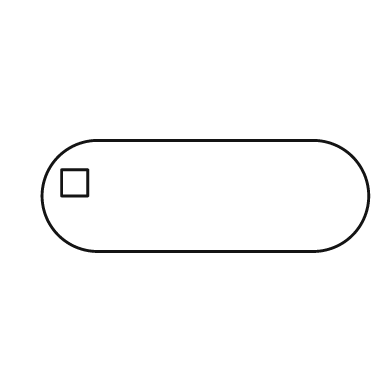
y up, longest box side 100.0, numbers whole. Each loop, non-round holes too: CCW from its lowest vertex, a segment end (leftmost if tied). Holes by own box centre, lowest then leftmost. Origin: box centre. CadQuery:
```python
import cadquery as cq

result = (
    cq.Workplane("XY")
    .moveTo(-33.0, -17.0)
    .lineTo(33.0, -17.0)
    .threePointArc((50.0, 0.0), (33.0, 17.0))
    .lineTo(-33.0, 17.0)
    .threePointArc((-50.0, 0.0), (-33.0, -17.0))
    .close()
    .moveTo(-44.0, 0.0)
    .lineTo(-36.0, 0.0)
    .lineTo(-36.0, 8.0)
    .lineTo(-44.0, 8.0)
    .close()
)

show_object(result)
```